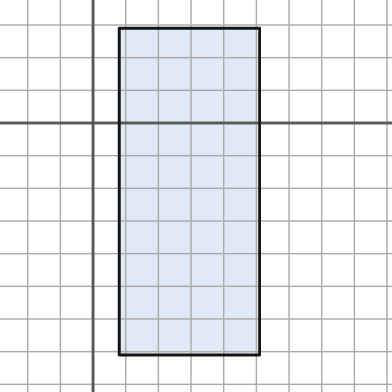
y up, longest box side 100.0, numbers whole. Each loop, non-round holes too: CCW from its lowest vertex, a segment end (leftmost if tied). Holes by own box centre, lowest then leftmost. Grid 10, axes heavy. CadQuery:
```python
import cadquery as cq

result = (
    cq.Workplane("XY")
    .moveTo(8.0, -71.0)
    .lineTo(51.0, -71.0)
    .lineTo(51.0, 29.0)
    .lineTo(8.0, 29.0)
    .close()
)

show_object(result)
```